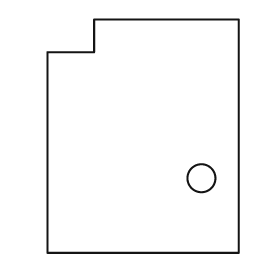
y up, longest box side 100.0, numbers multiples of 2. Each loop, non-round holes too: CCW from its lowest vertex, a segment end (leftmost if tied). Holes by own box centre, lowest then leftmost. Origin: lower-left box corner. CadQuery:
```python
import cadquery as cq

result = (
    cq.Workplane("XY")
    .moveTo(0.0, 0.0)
    .lineTo(82.0, 0.0)
    .lineTo(82.0, 100.0)
    .lineTo(20.0, 100.0)
    .lineTo(20.0, 86.0)
    .lineTo(0.0, 86.0)
    .close()
    .moveTo(66.0, 32.0)
    .circle(6.0)
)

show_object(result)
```